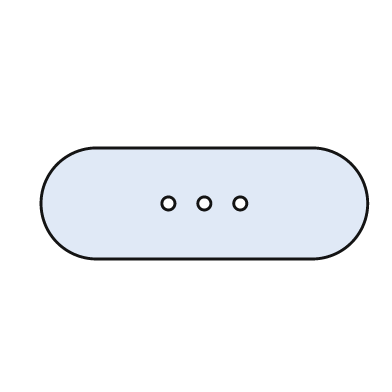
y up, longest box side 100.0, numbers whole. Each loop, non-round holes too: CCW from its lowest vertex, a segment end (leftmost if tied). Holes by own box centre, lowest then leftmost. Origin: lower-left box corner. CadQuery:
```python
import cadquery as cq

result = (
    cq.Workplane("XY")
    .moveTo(17.0, 0.0)
    .lineTo(83.0, 0.0)
    .threePointArc((100.0, 17.0), (83.0, 34.0))
    .lineTo(17.0, 34.0)
    .threePointArc((0.0, 17.0), (17.0, 0.0))
    .close()
    .moveTo(39.0, 17.0)
    .circle(2.0)
    .moveTo(50.0, 17.0)
    .circle(2.0)
    .moveTo(61.0, 17.0)
    .circle(2.0)
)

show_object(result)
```